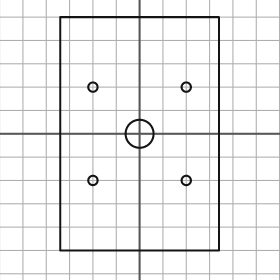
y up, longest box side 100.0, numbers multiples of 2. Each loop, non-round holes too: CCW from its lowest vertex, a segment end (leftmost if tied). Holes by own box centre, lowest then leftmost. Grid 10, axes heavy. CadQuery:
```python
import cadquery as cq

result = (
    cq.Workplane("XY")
    .moveTo(-34.0, -50.0)
    .lineTo(34.0, -50.0)
    .lineTo(34.0, 50.0)
    .lineTo(-34.0, 50.0)
    .close()
    .moveTo(-20.0, -20.0)
    .circle(2.0)
    .moveTo(20.0, -20.0)
    .circle(2.0)
    .moveTo(0.0, 0.0)
    .circle(6.0)
    .moveTo(-20.0, 20.0)
    .circle(2.0)
    .moveTo(20.0, 20.0)
    .circle(2.0)
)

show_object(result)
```